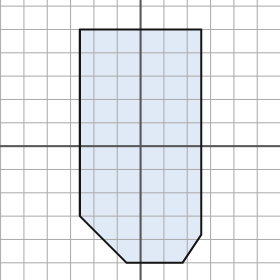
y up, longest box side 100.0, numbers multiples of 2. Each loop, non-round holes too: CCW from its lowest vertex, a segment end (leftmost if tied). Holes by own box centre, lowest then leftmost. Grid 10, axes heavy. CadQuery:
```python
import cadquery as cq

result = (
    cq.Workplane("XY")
    .moveTo(-6.0, -50.0)
    .lineTo(18.0, -50.0)
    .lineTo(26.0, -38.0)
    .lineTo(26.0, 50.0)
    .lineTo(-26.0, 50.0)
    .lineTo(-26.0, -30.0)
    .close()
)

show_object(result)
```